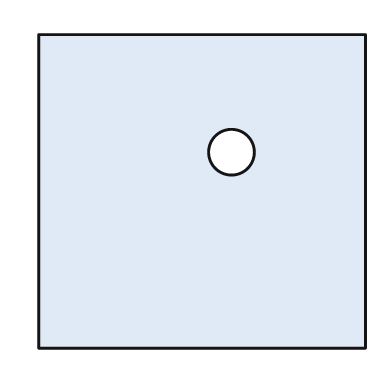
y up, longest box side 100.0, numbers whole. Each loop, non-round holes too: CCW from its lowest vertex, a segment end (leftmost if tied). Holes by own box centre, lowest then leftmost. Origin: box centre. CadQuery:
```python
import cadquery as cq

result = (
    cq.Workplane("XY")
    .moveTo(-50.0, -48.0)
    .lineTo(50.0, -48.0)
    .lineTo(50.0, 48.0)
    .lineTo(-50.0, 48.0)
    .close()
    .moveTo(9.0, 12.0)
    .circle(7.0)
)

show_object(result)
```